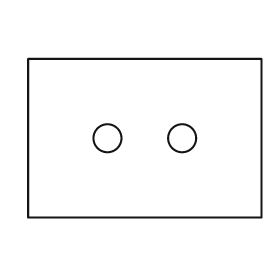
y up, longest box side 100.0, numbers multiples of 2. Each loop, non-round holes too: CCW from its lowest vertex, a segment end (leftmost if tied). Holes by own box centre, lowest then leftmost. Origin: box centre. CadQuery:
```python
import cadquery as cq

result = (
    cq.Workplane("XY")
    .moveTo(-50.0, -34.0)
    .lineTo(50.0, -34.0)
    .lineTo(50.0, 34.0)
    .lineTo(-50.0, 34.0)
    .close()
    .moveTo(-16.0, 0.0)
    .circle(6.0)
    .moveTo(16.0, 0.0)
    .circle(6.0)
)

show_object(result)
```